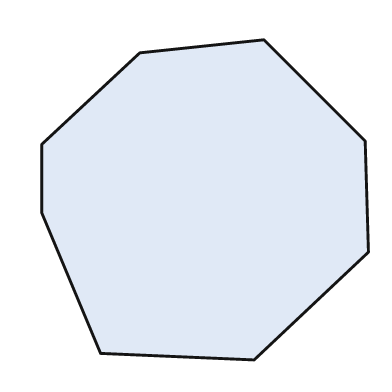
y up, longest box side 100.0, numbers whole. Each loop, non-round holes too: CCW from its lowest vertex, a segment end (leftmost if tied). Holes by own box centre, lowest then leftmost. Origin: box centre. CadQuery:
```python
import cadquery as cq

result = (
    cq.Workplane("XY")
    .moveTo(15.0, -49.0)
    .lineTo(50.0, -16.0)
    .lineTo(49.0, 18.0)
    .lineTo(18.0, 49.0)
    .lineTo(-20.0, 45.0)
    .lineTo(-50.0, 17.0)
    .lineTo(-50.0, -4.0)
    .lineTo(-32.0, -47.0)
    .close()
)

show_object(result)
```